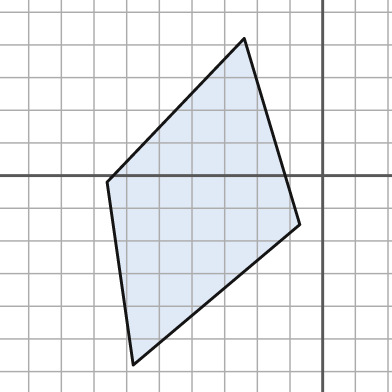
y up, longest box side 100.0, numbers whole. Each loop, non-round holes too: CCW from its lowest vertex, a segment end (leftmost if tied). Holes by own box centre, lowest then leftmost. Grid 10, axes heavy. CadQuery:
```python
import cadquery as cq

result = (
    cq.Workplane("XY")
    .moveTo(-58.0, -58.0)
    .lineTo(-7.0, -15.0)
    .lineTo(-24.0, 42.0)
    .lineTo(-66.0, -2.0)
    .close()
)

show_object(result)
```